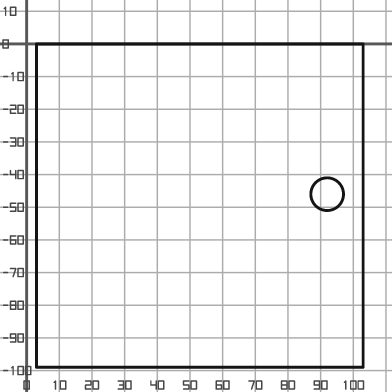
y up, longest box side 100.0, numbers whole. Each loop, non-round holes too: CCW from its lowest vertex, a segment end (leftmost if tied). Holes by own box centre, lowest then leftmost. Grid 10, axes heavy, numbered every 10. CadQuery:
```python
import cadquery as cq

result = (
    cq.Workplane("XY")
    .moveTo(3.0, -99.0)
    .lineTo(103.0, -99.0)
    .lineTo(103.0, 0.0)
    .lineTo(3.0, 0.0)
    .close()
    .moveTo(92.0, -46.0)
    .circle(5.0)
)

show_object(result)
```